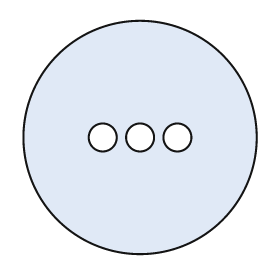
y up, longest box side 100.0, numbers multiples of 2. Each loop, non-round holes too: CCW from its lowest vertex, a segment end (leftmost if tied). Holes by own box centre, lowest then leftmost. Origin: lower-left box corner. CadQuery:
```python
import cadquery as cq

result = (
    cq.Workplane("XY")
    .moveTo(50.0, 50.0)
    .circle(50.0)
    .moveTo(34.0, 50.0)
    .circle(6.0)
    .moveTo(50.0, 50.0)
    .circle(6.0)
    .moveTo(66.0, 50.0)
    .circle(6.0)
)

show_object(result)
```